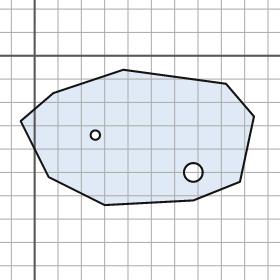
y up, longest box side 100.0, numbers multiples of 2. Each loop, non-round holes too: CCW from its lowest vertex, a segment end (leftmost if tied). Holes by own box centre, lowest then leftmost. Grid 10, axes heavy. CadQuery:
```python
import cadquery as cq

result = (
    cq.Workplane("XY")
    .moveTo(30.0, -64.0)
    .lineTo(68.0, -62.0)
    .lineTo(88.0, -54.0)
    .lineTo(94.0, -26.0)
    .lineTo(82.0, -12.0)
    .lineTo(38.0, -6.0)
    .lineTo(8.0, -16.0)
    .lineTo(-6.0, -28.0)
    .lineTo(6.0, -52.0)
    .close()
    .moveTo(68.0, -50.0)
    .circle(4.0)
    .moveTo(26.0, -34.0)
    .circle(2.0)
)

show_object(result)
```